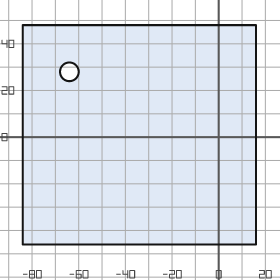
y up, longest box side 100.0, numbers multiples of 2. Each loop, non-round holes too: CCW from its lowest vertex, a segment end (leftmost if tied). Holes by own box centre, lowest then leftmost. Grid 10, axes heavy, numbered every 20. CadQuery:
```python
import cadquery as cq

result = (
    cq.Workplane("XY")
    .moveTo(-84.0, -46.0)
    .lineTo(16.0, -46.0)
    .lineTo(16.0, 48.0)
    .lineTo(-84.0, 48.0)
    .close()
    .moveTo(-64.0, 28.0)
    .circle(4.0)
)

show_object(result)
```